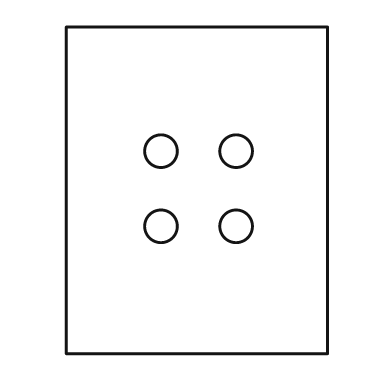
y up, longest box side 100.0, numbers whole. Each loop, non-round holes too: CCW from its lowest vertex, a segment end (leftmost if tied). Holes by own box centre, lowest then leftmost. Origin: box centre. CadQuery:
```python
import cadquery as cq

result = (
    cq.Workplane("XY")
    .moveTo(-40.0, -50.0)
    .lineTo(40.0, -50.0)
    .lineTo(40.0, 50.0)
    .lineTo(-40.0, 50.0)
    .close()
    .moveTo(-11.0, -11.0)
    .circle(5.0)
    .moveTo(12.0, -11.0)
    .circle(5.0)
    .moveTo(-11.0, 12.0)
    .circle(5.0)
    .moveTo(12.0, 12.0)
    .circle(5.0)
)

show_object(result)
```